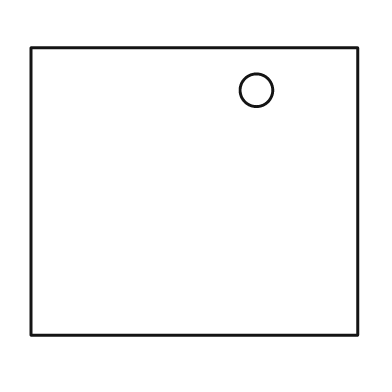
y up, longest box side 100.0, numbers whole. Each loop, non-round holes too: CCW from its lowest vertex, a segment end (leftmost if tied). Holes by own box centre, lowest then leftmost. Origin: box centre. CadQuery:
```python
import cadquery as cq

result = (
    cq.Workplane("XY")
    .moveTo(-50.0, -44.0)
    .lineTo(50.0, -44.0)
    .lineTo(50.0, 44.0)
    .lineTo(-50.0, 44.0)
    .close()
    .moveTo(19.0, 31.0)
    .circle(5.0)
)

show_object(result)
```